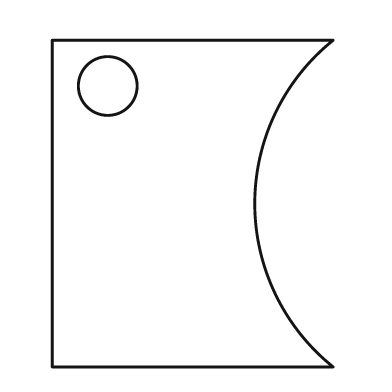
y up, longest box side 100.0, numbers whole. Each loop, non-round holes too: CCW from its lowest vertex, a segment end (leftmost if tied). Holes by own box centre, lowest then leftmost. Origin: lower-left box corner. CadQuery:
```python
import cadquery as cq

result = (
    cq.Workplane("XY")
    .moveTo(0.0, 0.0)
    .lineTo(86.0, 0.0)
    .threePointArc((62.0, 50.0), (86.0, 100.0))
    .lineTo(0.0, 100.0)
    .close()
    .moveTo(17.0, 86.0)
    .circle(9.0)
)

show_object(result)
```